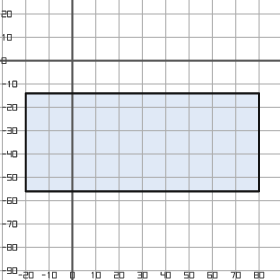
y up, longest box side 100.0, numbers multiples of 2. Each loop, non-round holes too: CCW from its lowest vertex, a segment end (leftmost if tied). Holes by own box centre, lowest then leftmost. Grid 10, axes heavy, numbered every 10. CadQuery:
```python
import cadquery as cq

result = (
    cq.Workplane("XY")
    .moveTo(-20.0, -56.0)
    .lineTo(80.0, -56.0)
    .lineTo(80.0, -14.0)
    .lineTo(-20.0, -14.0)
    .close()
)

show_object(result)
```